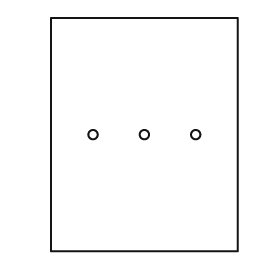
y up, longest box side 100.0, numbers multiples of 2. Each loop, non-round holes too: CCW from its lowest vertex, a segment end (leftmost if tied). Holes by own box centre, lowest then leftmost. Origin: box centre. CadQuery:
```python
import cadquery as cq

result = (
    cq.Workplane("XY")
    .moveTo(-40.0, -50.0)
    .lineTo(40.0, -50.0)
    .lineTo(40.0, 50.0)
    .lineTo(-40.0, 50.0)
    .close()
    .moveTo(-22.0, 0.0)
    .circle(2.0)
    .moveTo(0.0, 0.0)
    .circle(2.0)
    .moveTo(22.0, 0.0)
    .circle(2.0)
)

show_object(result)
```